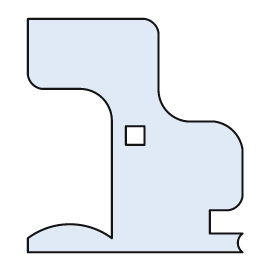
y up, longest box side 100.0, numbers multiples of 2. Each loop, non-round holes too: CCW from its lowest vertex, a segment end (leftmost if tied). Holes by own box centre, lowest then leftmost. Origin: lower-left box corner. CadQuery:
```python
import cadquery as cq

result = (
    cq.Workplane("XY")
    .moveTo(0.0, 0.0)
    .lineTo(92.0, 0.0)
    .threePointArc((90.0, 4.0), (92.0, 8.0))
    .lineTo(78.0, 8.0)
    .lineTo(78.0, 18.0)
    .lineTo(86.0, 18.0)
    .threePointArc((90.0, 20.0), (92.0, 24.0))
    .lineTo(92.0, 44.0)
    .threePointArc((88.0, 52.0), (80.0, 56.0))
    .lineTo(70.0, 56.0)
    .threePointArc((60.0, 60.0), (56.0, 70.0))
    .lineTo(56.0, 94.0)
    .threePointArc((54.0, 98.0), (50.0, 100.0))
    .lineTo(0.0, 100.0)
    .lineTo(0.0, 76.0)
    .threePointArc((2.0, 72.0), (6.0, 70.0))
    .lineTo(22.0, 70.0)
    .threePointArc((32.0, 66.0), (36.0, 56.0))
    .lineTo(36.0, 6.0)
    .threePointArc((18.0, 12.0), (0.0, 6.0))
    .close()
    .moveTo(42.0, 46.0)
    .lineTo(50.0, 46.0)
    .lineTo(50.0, 54.0)
    .lineTo(42.0, 54.0)
    .close()
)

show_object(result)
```